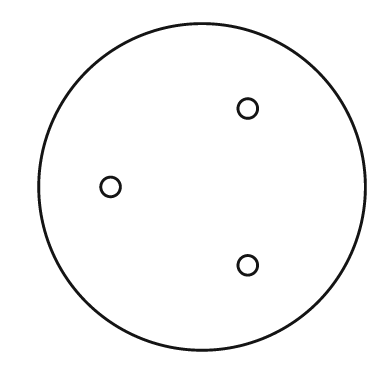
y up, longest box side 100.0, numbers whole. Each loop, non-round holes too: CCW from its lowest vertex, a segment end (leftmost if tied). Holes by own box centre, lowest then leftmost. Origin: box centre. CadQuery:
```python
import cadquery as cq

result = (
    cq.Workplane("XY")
    .moveTo(0.0, 0.0)
    .circle(50.0)
    .moveTo(14.0, -24.0)
    .circle(3.0)
    .moveTo(-28.0, 0.0)
    .circle(3.0)
    .moveTo(14.0, 24.0)
    .circle(3.0)
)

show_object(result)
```